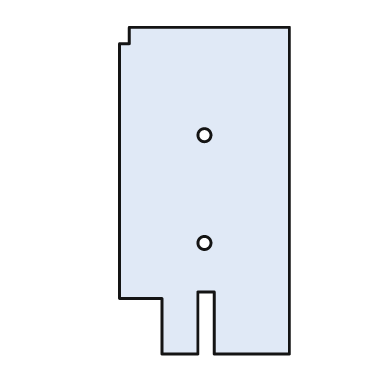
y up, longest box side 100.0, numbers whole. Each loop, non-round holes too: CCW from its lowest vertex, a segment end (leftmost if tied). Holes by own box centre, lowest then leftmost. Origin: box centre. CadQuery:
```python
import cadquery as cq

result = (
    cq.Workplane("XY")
    .moveTo(-13.0, -50.0)
    .lineTo(-2.0, -50.0)
    .lineTo(-2.0, -31.0)
    .lineTo(3.0, -31.0)
    .lineTo(3.0, -50.0)
    .lineTo(26.0, -50.0)
    .lineTo(26.0, 50.0)
    .lineTo(-23.0, 50.0)
    .lineTo(-23.0, 45.0)
    .lineTo(-26.0, 45.0)
    .lineTo(-26.0, -33.0)
    .lineTo(-13.0, -33.0)
    .close()
    .moveTo(0.0, -16.0)
    .circle(2.0)
    .moveTo(0.0, 17.0)
    .circle(2.0)
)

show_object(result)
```